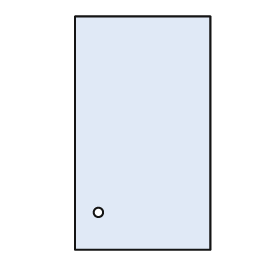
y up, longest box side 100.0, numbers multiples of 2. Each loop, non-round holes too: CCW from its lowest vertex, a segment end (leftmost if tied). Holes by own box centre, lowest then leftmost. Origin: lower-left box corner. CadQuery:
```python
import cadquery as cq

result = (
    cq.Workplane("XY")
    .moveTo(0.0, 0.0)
    .lineTo(58.0, 0.0)
    .lineTo(58.0, 100.0)
    .lineTo(0.0, 100.0)
    .close()
    .moveTo(10.0, 16.0)
    .circle(2.0)
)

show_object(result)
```